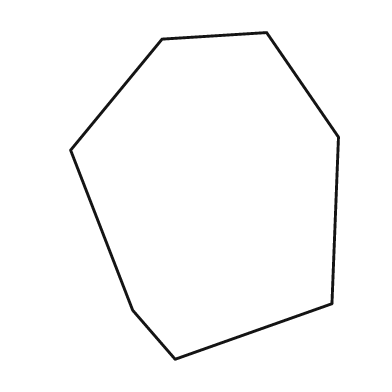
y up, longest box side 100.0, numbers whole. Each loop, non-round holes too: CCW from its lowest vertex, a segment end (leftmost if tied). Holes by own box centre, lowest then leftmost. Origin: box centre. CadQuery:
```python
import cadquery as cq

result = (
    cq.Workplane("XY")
    .moveTo(-9.0, -50.0)
    .lineTo(39.0, -33.0)
    .lineTo(41.0, 18.0)
    .lineTo(19.0, 50.0)
    .lineTo(-13.0, 48.0)
    .lineTo(-41.0, 14.0)
    .lineTo(-22.0, -35.0)
    .close()
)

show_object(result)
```